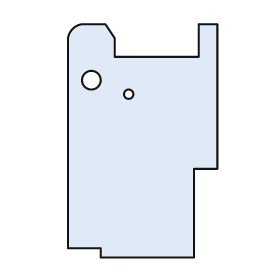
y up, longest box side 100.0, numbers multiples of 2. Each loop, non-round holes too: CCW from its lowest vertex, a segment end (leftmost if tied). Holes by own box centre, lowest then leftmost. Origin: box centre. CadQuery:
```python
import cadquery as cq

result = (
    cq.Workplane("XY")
    .moveTo(-18.0, -50.0)
    .lineTo(22.0, -50.0)
    .lineTo(22.0, -12.0)
    .lineTo(32.0, -12.0)
    .lineTo(32.0, 50.0)
    .lineTo(24.0, 50.0)
    .lineTo(24.0, 36.0)
    .lineTo(-12.0, 36.0)
    .lineTo(-12.0, 44.0)
    .lineTo(-16.0, 50.0)
    .lineTo(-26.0, 50.0)
    .threePointArc((-30.0, 48.0), (-32.0, 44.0))
    .lineTo(-32.0, -46.0)
    .lineTo(-18.0, -46.0)
    .close()
    .moveTo(-6.0, 20.0)
    .circle(2.0)
    .moveTo(-22.0, 26.0)
    .circle(4.0)
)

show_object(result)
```